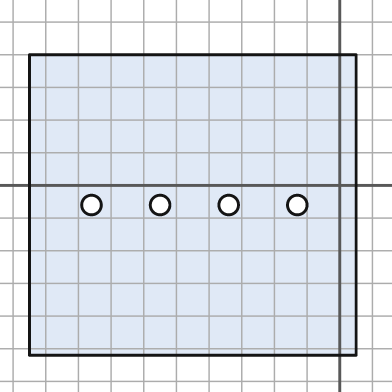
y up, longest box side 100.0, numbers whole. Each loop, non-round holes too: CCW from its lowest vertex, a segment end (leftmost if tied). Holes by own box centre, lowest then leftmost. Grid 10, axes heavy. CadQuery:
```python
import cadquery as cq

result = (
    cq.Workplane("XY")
    .moveTo(-95.0, -52.0)
    .lineTo(5.0, -52.0)
    .lineTo(5.0, 40.0)
    .lineTo(-95.0, 40.0)
    .close()
    .moveTo(-76.0, -6.0)
    .circle(3.0)
    .moveTo(-55.0, -6.0)
    .circle(3.0)
    .moveTo(-34.0, -6.0)
    .circle(3.0)
    .moveTo(-13.0, -6.0)
    .circle(3.0)
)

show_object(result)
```